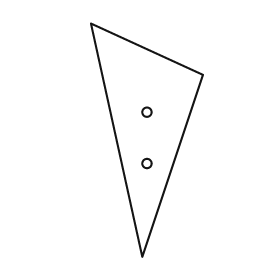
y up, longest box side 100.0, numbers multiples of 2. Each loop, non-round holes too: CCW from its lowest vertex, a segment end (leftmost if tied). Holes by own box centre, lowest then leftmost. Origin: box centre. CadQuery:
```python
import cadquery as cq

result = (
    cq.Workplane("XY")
    .moveTo(-2.0, -50.0)
    .lineTo(24.0, 28.0)
    .lineTo(-24.0, 50.0)
    .close()
    .moveTo(0.0, -10.0)
    .circle(2.0)
    .moveTo(0.0, 12.0)
    .circle(2.0)
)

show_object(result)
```